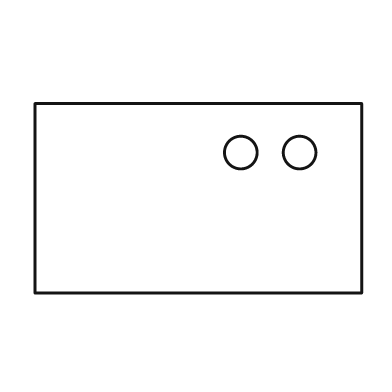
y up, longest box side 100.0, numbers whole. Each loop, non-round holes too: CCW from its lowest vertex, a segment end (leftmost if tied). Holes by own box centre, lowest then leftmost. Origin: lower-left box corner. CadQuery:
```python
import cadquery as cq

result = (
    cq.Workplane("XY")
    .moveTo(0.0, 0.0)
    .lineTo(100.0, 0.0)
    .lineTo(100.0, 58.0)
    .lineTo(0.0, 58.0)
    .close()
    .moveTo(63.0, 43.0)
    .circle(5.0)
    .moveTo(81.0, 43.0)
    .circle(5.0)
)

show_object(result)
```